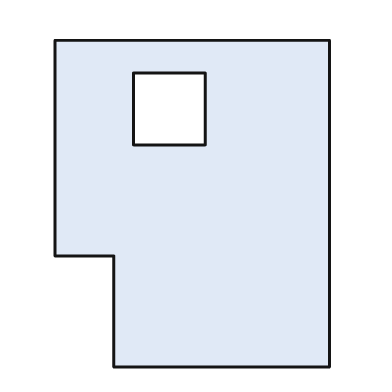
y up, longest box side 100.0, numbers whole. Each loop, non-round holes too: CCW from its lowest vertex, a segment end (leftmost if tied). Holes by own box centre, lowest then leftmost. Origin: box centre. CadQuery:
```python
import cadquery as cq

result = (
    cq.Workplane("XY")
    .moveTo(-24.0, -50.0)
    .lineTo(42.0, -50.0)
    .lineTo(42.0, 50.0)
    .lineTo(-42.0, 50.0)
    .lineTo(-42.0, -16.0)
    .lineTo(-24.0, -16.0)
    .close()
    .moveTo(-18.0, 18.0)
    .lineTo(4.0, 18.0)
    .lineTo(4.0, 40.0)
    .lineTo(-18.0, 40.0)
    .close()
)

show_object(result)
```